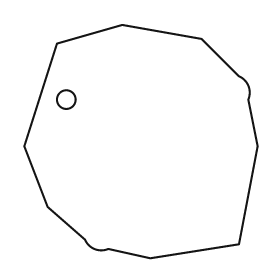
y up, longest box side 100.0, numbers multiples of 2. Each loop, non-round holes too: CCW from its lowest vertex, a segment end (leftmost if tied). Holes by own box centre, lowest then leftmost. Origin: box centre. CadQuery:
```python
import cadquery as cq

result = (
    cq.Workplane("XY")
    .moveTo(4.0, -50.0)
    .lineTo(42.0, -44.0)
    .lineTo(50.0, -2.0)
    .lineTo(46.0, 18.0)
    .threePointArc((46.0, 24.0), (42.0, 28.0))
    .lineTo(26.0, 44.0)
    .lineTo(-8.0, 50.0)
    .lineTo(-36.0, 42.0)
    .lineTo(-50.0, -2.0)
    .lineTo(-40.0, -28.0)
    .lineTo(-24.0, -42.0)
    .threePointArc((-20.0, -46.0), (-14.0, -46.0))
    .close()
    .moveTo(-32.0, 18.0)
    .circle(4.0)
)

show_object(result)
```